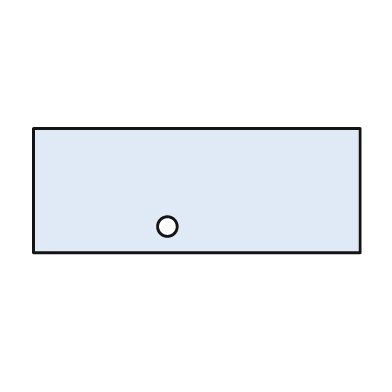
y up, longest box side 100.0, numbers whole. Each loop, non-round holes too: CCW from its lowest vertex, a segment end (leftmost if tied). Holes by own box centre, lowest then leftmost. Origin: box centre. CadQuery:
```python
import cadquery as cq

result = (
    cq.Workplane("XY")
    .moveTo(-50.0, -19.0)
    .lineTo(50.0, -19.0)
    .lineTo(50.0, 19.0)
    .lineTo(-50.0, 19.0)
    .close()
    .moveTo(-9.0, -11.0)
    .circle(3.0)
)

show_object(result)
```